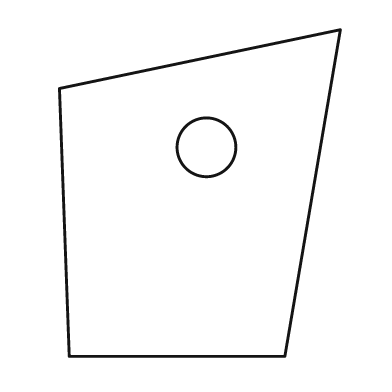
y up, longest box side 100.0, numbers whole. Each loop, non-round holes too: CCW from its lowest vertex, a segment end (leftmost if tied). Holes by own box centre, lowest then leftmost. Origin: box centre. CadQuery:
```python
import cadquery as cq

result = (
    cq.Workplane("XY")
    .moveTo(-40.0, -50.0)
    .lineTo(26.0, -50.0)
    .lineTo(43.0, 50.0)
    .lineTo(-43.0, 32.0)
    .close()
    .moveTo(2.0, 14.0)
    .circle(9.0)
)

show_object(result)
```